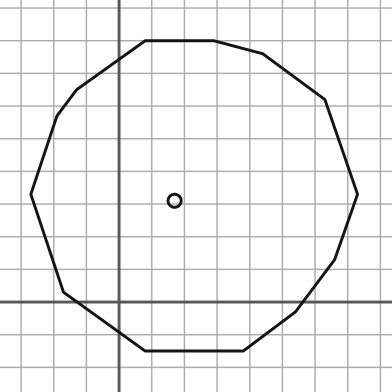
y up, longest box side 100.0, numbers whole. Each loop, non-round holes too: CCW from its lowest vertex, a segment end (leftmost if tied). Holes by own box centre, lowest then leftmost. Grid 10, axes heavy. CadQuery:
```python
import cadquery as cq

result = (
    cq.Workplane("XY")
    .moveTo(8.0, -15.0)
    .lineTo(38.0, -15.0)
    .lineTo(54.0, -3.0)
    .lineTo(66.0, 13.0)
    .lineTo(73.0, 33.0)
    .lineTo(63.0, 62.0)
    .lineTo(44.0, 76.0)
    .lineTo(29.0, 80.0)
    .lineTo(8.0, 80.0)
    .lineTo(-13.0, 65.0)
    .lineTo(-19.0, 57.0)
    .lineTo(-27.0, 33.0)
    .lineTo(-17.0, 3.0)
    .close()
    .moveTo(17.0, 31.0)
    .circle(2.0)
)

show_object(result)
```